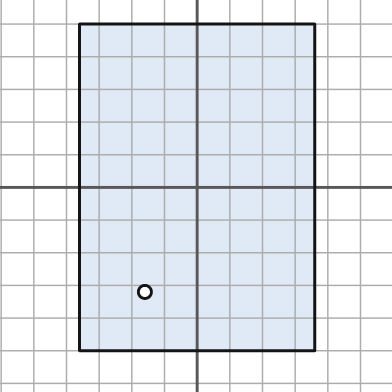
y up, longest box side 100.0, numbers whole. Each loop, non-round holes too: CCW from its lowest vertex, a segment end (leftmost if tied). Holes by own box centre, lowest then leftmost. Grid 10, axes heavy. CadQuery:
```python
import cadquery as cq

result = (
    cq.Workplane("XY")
    .moveTo(-36.0, -50.0)
    .lineTo(36.0, -50.0)
    .lineTo(36.0, 50.0)
    .lineTo(-36.0, 50.0)
    .close()
    .moveTo(-16.0, -32.0)
    .circle(2.0)
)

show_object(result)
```